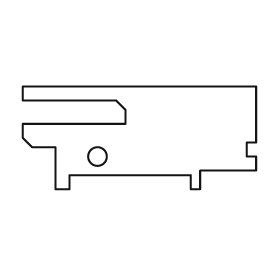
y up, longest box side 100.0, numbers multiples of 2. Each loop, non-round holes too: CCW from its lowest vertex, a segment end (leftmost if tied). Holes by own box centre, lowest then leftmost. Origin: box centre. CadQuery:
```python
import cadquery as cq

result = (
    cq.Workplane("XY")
    .moveTo(-36.0, -22.0)
    .lineTo(-30.0, -22.0)
    .lineTo(-30.0, -16.0)
    .lineTo(22.0, -16.0)
    .lineTo(22.0, -22.0)
    .lineTo(26.0, -22.0)
    .lineTo(26.0, -14.0)
    .lineTo(50.0, -14.0)
    .lineTo(50.0, -8.0)
    .lineTo(46.0, -8.0)
    .lineTo(46.0, -2.0)
    .lineTo(50.0, -2.0)
    .lineTo(50.0, 22.0)
    .lineTo(-50.0, 22.0)
    .lineTo(-50.0, 16.0)
    .lineTo(-10.0, 16.0)
    .lineTo(-6.0, 12.0)
    .lineTo(-6.0, 6.0)
    .lineTo(-50.0, 6.0)
    .lineTo(-50.0, 0.0)
    .lineTo(-46.0, -4.0)
    .lineTo(-36.0, -4.0)
    .close()
    .moveTo(-18.0, -8.0)
    .circle(4.0)
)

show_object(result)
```